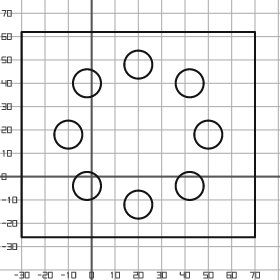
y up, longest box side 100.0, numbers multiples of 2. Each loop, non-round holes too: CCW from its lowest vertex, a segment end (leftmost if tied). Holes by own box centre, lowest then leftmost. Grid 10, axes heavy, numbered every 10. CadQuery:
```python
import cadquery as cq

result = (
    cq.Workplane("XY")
    .moveTo(-30.0, -26.0)
    .lineTo(70.0, -26.0)
    .lineTo(70.0, 62.0)
    .lineTo(-30.0, 62.0)
    .close()
    .moveTo(20.0, -12.0)
    .circle(6.0)
    .moveTo(-2.0, -4.0)
    .circle(6.0)
    .moveTo(42.0, -4.0)
    .circle(6.0)
    .moveTo(-10.0, 18.0)
    .circle(6.0)
    .moveTo(50.0, 18.0)
    .circle(6.0)
    .moveTo(-2.0, 40.0)
    .circle(6.0)
    .moveTo(42.0, 40.0)
    .circle(6.0)
    .moveTo(20.0, 48.0)
    .circle(6.0)
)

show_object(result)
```